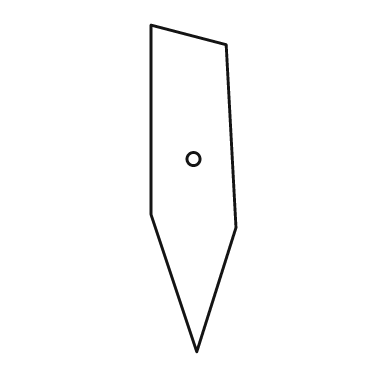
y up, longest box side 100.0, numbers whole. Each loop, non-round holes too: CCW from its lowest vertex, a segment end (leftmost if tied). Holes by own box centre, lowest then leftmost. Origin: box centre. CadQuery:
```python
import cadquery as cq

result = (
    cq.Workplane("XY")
    .moveTo(1.0, -50.0)
    .lineTo(13.0, -12.0)
    .lineTo(10.0, 44.0)
    .lineTo(-13.0, 50.0)
    .lineTo(-13.0, -8.0)
    .close()
    .moveTo(0.0, 9.0)
    .circle(2.0)
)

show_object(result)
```